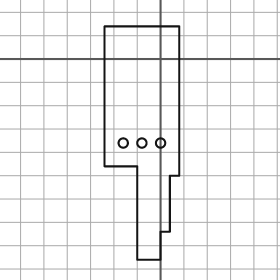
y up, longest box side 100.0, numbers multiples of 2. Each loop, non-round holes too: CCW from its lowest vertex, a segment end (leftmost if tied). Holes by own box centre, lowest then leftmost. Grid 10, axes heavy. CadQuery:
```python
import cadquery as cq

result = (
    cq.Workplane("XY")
    .moveTo(-10.0, -86.0)
    .lineTo(0.0, -86.0)
    .lineTo(0.0, -74.0)
    .lineTo(4.0, -74.0)
    .lineTo(4.0, -50.0)
    .lineTo(8.0, -50.0)
    .lineTo(8.0, 14.0)
    .lineTo(-24.0, 14.0)
    .lineTo(-24.0, -46.0)
    .lineTo(-10.0, -46.0)
    .close()
    .moveTo(-16.0, -36.0)
    .circle(2.0)
    .moveTo(-8.0, -36.0)
    .circle(2.0)
    .moveTo(0.0, -36.0)
    .circle(2.0)
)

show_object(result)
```